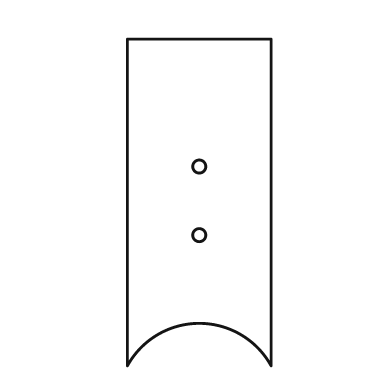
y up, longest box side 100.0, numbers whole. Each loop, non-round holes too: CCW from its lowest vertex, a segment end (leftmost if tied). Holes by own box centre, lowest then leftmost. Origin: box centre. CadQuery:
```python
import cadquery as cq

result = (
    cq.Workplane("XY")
    .moveTo(-22.0, -50.0)
    .threePointArc((0.0, -37.0), (22.0, -50.0))
    .lineTo(22.0, 50.0)
    .lineTo(-22.0, 50.0)
    .close()
    .moveTo(0.0, -10.0)
    .circle(2.0)
    .moveTo(0.0, 11.0)
    .circle(2.0)
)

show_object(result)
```